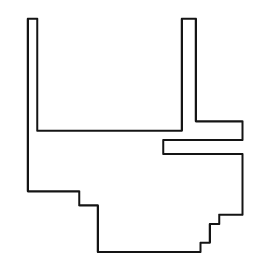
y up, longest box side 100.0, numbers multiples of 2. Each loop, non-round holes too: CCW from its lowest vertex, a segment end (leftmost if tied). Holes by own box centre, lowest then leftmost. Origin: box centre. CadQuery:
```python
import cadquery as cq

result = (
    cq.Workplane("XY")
    .moveTo(-16.0, -50.0)
    .lineTo(28.0, -50.0)
    .lineTo(28.0, -46.0)
    .lineTo(32.0, -46.0)
    .lineTo(32.0, -38.0)
    .lineTo(36.0, -38.0)
    .lineTo(36.0, -34.0)
    .lineTo(46.0, -34.0)
    .lineTo(46.0, -8.0)
    .lineTo(12.0, -8.0)
    .lineTo(12.0, -2.0)
    .lineTo(46.0, -2.0)
    .lineTo(46.0, 6.0)
    .lineTo(26.0, 6.0)
    .lineTo(26.0, 50.0)
    .lineTo(20.0, 50.0)
    .lineTo(20.0, 2.0)
    .lineTo(-42.0, 2.0)
    .lineTo(-42.0, 50.0)
    .lineTo(-46.0, 50.0)
    .lineTo(-46.0, -24.0)
    .lineTo(-24.0, -24.0)
    .lineTo(-24.0, -30.0)
    .lineTo(-16.0, -30.0)
    .close()
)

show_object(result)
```